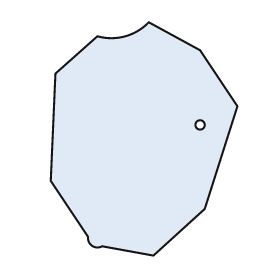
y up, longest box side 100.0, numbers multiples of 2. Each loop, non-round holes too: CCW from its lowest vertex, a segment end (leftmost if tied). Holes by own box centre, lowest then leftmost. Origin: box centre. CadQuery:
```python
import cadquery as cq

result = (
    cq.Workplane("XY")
    .moveTo(4.0, -50.0)
    .lineTo(26.0, -30.0)
    .lineTo(40.0, 14.0)
    .lineTo(24.0, 38.0)
    .lineTo(2.0, 50.0)
    .threePointArc((-8.0, 44.0), (-20.0, 44.0))
    .lineTo(-38.0, 28.0)
    .lineTo(-40.0, -18.0)
    .lineTo(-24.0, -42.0)
    .threePointArc((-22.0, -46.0), (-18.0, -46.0))
    .close()
    .moveTo(24.0, 6.0)
    .circle(2.0)
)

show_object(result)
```